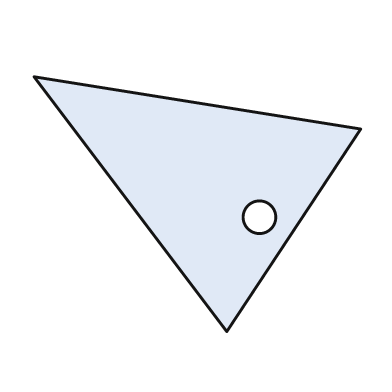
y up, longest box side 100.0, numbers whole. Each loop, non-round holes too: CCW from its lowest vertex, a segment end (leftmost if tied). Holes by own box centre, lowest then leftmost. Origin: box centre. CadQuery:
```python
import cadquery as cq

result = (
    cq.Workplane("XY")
    .moveTo(9.0, -39.0)
    .lineTo(50.0, 23.0)
    .lineTo(-50.0, 39.0)
    .close()
    .moveTo(19.0, -4.0)
    .circle(5.0)
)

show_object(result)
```